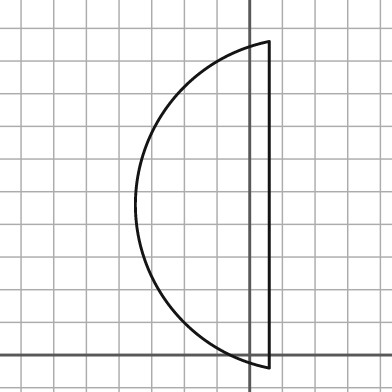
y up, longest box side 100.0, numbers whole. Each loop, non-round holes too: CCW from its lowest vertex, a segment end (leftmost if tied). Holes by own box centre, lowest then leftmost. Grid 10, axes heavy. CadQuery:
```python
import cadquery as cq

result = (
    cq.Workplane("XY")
    .moveTo(6.0, -4.0)
    .lineTo(6.0, 96.0)
    .threePointArc((-35.0, 46.0), (6.0, -4.0))
    .close()
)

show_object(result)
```